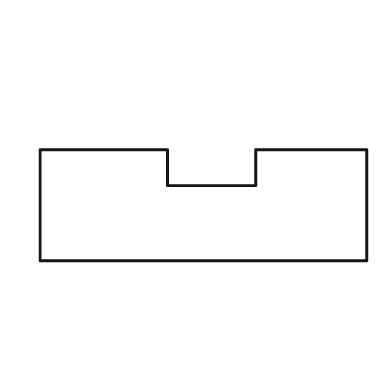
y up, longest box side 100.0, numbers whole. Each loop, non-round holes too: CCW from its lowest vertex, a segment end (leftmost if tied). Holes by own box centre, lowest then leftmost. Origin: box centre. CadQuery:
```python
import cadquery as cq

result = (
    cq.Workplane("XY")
    .moveTo(-50.0, -17.0)
    .lineTo(50.0, -17.0)
    .lineTo(50.0, 17.0)
    .lineTo(16.0, 17.0)
    .lineTo(16.0, 6.0)
    .lineTo(-11.0, 6.0)
    .lineTo(-11.0, 17.0)
    .lineTo(-50.0, 17.0)
    .close()
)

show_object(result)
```